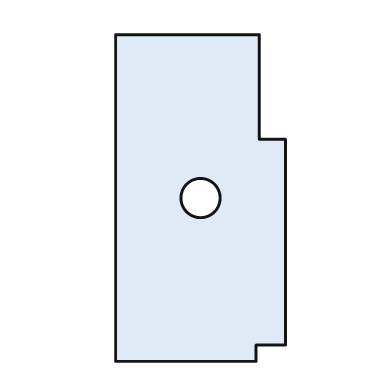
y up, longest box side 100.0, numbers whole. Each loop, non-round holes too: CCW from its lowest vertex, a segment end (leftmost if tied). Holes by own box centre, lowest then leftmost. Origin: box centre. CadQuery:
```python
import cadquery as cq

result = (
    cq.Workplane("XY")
    .moveTo(-26.0, -50.0)
    .lineTo(17.0, -50.0)
    .lineTo(17.0, -45.0)
    .lineTo(26.0, -45.0)
    .lineTo(26.0, 18.0)
    .lineTo(18.0, 18.0)
    .lineTo(18.0, 50.0)
    .lineTo(-26.0, 50.0)
    .close()
    .moveTo(0.0, 0.0)
    .circle(6.0)
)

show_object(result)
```